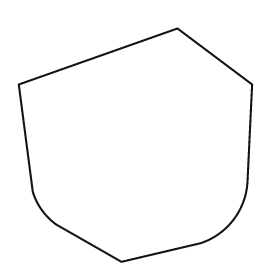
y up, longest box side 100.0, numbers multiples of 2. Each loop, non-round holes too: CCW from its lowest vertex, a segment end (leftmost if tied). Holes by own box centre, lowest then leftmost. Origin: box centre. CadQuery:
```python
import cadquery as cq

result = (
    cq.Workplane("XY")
    .moveTo(-6.0, -50.0)
    .lineTo(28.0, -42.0)
    .threePointArc((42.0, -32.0), (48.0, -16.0))
    .lineTo(50.0, 26.0)
    .lineTo(18.0, 50.0)
    .lineTo(-50.0, 26.0)
    .lineTo(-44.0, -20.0)
    .threePointArc((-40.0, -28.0), (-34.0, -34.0))
    .close()
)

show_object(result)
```